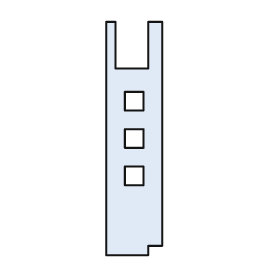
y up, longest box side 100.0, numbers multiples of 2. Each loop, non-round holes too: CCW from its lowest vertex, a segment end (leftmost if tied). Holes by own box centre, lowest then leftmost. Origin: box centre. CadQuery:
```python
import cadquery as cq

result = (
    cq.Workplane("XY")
    .moveTo(-12.0, -50.0)
    .lineTo(6.0, -50.0)
    .lineTo(6.0, -46.0)
    .lineTo(12.0, -46.0)
    .lineTo(12.0, 50.0)
    .lineTo(6.0, 50.0)
    .lineTo(6.0, 30.0)
    .lineTo(-8.0, 30.0)
    .lineTo(-8.0, 50.0)
    .lineTo(-12.0, 50.0)
    .close()
    .moveTo(-4.0, -20.0)
    .lineTo(4.0, -20.0)
    .lineTo(4.0, -12.0)
    .lineTo(-4.0, -12.0)
    .close()
    .moveTo(-4.0, -4.0)
    .lineTo(4.0, -4.0)
    .lineTo(4.0, 4.0)
    .lineTo(-4.0, 4.0)
    .close()
    .moveTo(-4.0, 12.0)
    .lineTo(4.0, 12.0)
    .lineTo(4.0, 20.0)
    .lineTo(-4.0, 20.0)
    .close()
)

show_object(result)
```